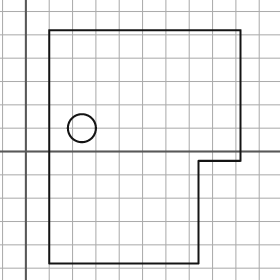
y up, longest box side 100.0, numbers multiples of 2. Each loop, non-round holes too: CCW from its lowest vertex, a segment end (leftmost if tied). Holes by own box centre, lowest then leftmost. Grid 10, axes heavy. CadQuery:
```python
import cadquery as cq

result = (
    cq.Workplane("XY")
    .moveTo(10.0, -48.0)
    .lineTo(74.0, -48.0)
    .lineTo(74.0, -4.0)
    .lineTo(92.0, -4.0)
    .lineTo(92.0, 52.0)
    .lineTo(10.0, 52.0)
    .close()
    .moveTo(24.0, 10.0)
    .circle(6.0)
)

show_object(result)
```